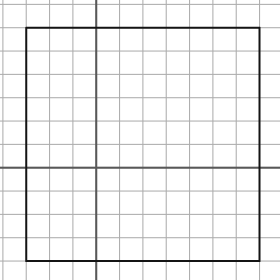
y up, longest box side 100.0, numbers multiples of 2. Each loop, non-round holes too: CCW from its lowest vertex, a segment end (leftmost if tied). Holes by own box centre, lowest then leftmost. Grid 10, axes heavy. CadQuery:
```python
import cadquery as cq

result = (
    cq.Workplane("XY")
    .moveTo(-30.0, -40.0)
    .lineTo(70.0, -40.0)
    .lineTo(70.0, 60.0)
    .lineTo(-30.0, 60.0)
    .close()
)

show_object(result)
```